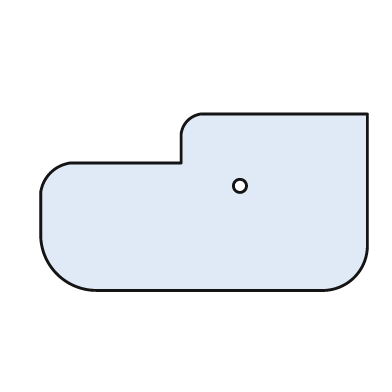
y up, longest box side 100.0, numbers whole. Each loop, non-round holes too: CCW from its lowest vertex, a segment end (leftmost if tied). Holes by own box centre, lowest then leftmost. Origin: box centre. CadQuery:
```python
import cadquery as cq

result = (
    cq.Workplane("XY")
    .moveTo(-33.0, -27.0)
    .lineTo(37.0, -27.0)
    .threePointArc((46.0, -23.0), (50.0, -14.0))
    .lineTo(50.0, 27.0)
    .lineTo(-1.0, 27.0)
    .threePointArc((-5.0, 25.0), (-7.0, 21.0))
    .lineTo(-7.0, 12.0)
    .lineTo(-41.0, 12.0)
    .threePointArc((-47.0, 9.0), (-50.0, 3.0))
    .lineTo(-50.0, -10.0)
    .threePointArc((-45.0, -22.0), (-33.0, -27.0))
    .close()
    .moveTo(11.0, 5.0)
    .circle(2.0)
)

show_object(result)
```